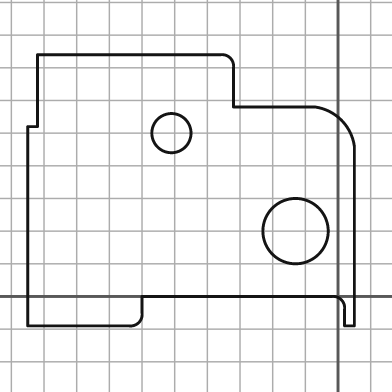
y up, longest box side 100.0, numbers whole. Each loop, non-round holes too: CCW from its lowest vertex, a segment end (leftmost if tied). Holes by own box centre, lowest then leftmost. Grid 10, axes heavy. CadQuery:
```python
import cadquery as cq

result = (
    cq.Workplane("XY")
    .moveTo(-95.0, -9.0)
    .lineTo(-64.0, -9.0)
    .threePointArc((-61.0, -8.0), (-60.0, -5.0))
    .lineTo(-60.0, 0.0)
    .lineTo(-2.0, 0.0)
    .threePointArc((1.0, -1.0), (2.0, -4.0))
    .lineTo(2.0, -9.0)
    .lineTo(5.0, -9.0)
    .lineTo(5.0, 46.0)
    .threePointArc((1.0, 54.0), (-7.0, 58.0))
    .lineTo(-32.0, 58.0)
    .lineTo(-32.0, 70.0)
    .threePointArc((-33.0, 73.0), (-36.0, 74.0))
    .lineTo(-92.0, 74.0)
    .lineTo(-92.0, 52.0)
    .lineTo(-95.0, 52.0)
    .close()
    .moveTo(-13.0, 20.0)
    .circle(10.0)
    .moveTo(-51.0, 50.0)
    .circle(6.0)
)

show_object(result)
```